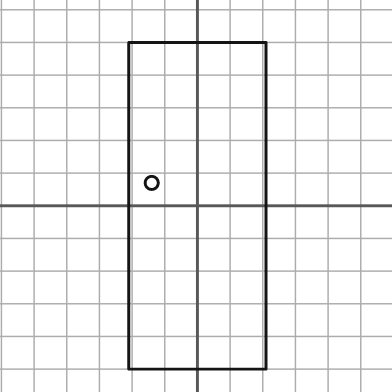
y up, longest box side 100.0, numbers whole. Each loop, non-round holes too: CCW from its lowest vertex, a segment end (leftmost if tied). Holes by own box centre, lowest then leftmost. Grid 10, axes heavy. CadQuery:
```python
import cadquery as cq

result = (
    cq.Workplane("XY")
    .moveTo(-21.0, -50.0)
    .lineTo(21.0, -50.0)
    .lineTo(21.0, 50.0)
    .lineTo(-21.0, 50.0)
    .close()
    .moveTo(-14.0, 7.0)
    .circle(2.0)
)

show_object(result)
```